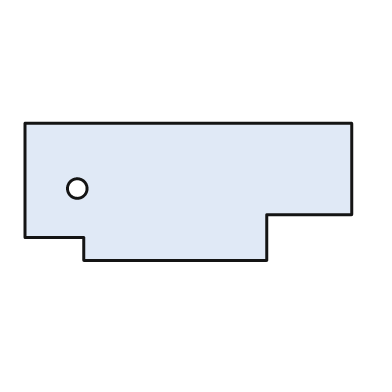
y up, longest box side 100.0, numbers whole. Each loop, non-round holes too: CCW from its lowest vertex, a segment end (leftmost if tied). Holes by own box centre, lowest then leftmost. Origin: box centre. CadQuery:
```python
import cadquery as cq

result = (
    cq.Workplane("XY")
    .moveTo(-32.0, -21.0)
    .lineTo(24.0, -21.0)
    .lineTo(24.0, -7.0)
    .lineTo(50.0, -7.0)
    .lineTo(50.0, 21.0)
    .lineTo(-50.0, 21.0)
    .lineTo(-50.0, -14.0)
    .lineTo(-32.0, -14.0)
    .close()
    .moveTo(-34.0, 1.0)
    .circle(3.0)
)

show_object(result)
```